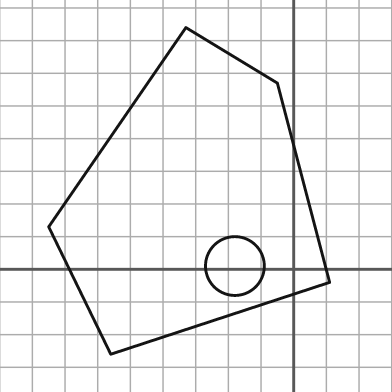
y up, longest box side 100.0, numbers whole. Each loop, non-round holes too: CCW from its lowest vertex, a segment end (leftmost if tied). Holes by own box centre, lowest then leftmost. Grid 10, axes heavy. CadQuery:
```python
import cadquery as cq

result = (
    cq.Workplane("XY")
    .moveTo(-56.0, -26.0)
    .lineTo(11.0, -4.0)
    .lineTo(-5.0, 57.0)
    .lineTo(-33.0, 74.0)
    .lineTo(-75.0, 13.0)
    .close()
    .moveTo(-18.0, 1.0)
    .circle(9.0)
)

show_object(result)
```